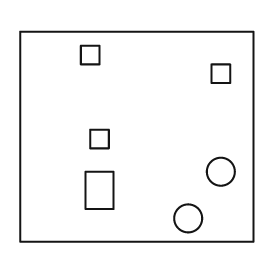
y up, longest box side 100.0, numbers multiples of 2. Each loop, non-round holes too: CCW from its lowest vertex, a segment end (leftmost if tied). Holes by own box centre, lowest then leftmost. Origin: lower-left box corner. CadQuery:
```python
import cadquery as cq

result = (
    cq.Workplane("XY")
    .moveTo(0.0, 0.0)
    .lineTo(100.0, 0.0)
    .lineTo(100.0, 90.0)
    .lineTo(0.0, 90.0)
    .close()
    .moveTo(72.0, 10.0)
    .circle(6.0)
    .moveTo(28.0, 14.0)
    .lineTo(40.0, 14.0)
    .lineTo(40.0, 30.0)
    .lineTo(28.0, 30.0)
    .close()
    .moveTo(86.0, 30.0)
    .circle(6.0)
    .moveTo(30.0, 40.0)
    .lineTo(38.0, 40.0)
    .lineTo(38.0, 48.0)
    .lineTo(30.0, 48.0)
    .close()
    .moveTo(82.0, 68.0)
    .lineTo(90.0, 68.0)
    .lineTo(90.0, 76.0)
    .lineTo(82.0, 76.0)
    .close()
    .moveTo(26.0, 76.0)
    .lineTo(34.0, 76.0)
    .lineTo(34.0, 84.0)
    .lineTo(26.0, 84.0)
    .close()
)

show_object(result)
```